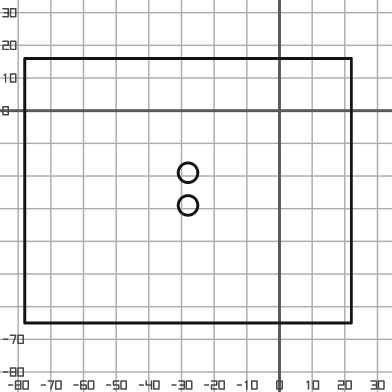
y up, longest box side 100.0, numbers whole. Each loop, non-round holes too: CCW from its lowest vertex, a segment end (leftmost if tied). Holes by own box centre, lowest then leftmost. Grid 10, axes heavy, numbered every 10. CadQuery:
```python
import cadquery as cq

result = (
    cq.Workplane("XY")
    .moveTo(-78.0, -65.0)
    .lineTo(22.0, -65.0)
    .lineTo(22.0, 16.0)
    .lineTo(-78.0, 16.0)
    .close()
    .moveTo(-28.0, -29.0)
    .circle(3.0)
    .moveTo(-28.0, -19.0)
    .circle(3.0)
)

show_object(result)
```